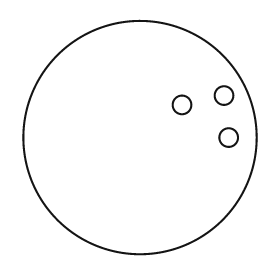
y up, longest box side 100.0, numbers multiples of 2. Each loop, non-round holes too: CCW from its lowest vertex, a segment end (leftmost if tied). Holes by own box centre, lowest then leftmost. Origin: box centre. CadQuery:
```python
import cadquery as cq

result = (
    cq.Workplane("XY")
    .moveTo(0.0, 0.0)
    .circle(50.0)
    .moveTo(38.0, 0.0)
    .circle(4.0)
    .moveTo(18.0, 14.0)
    .circle(4.0)
    .moveTo(36.0, 18.0)
    .circle(4.0)
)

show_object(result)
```